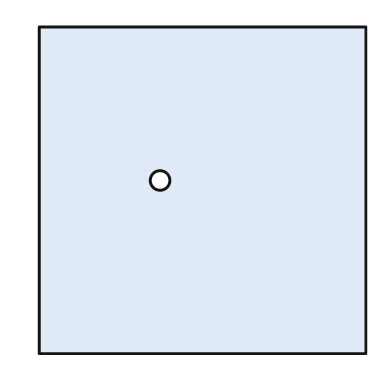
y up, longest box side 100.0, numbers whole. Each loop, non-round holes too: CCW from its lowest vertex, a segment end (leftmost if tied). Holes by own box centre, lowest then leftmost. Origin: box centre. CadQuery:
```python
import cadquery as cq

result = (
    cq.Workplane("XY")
    .moveTo(-50.0, -50.0)
    .lineTo(50.0, -50.0)
    .lineTo(50.0, 50.0)
    .lineTo(-50.0, 50.0)
    .close()
    .moveTo(-13.0, 3.0)
    .circle(3.0)
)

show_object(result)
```